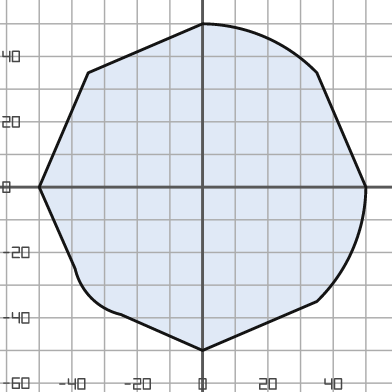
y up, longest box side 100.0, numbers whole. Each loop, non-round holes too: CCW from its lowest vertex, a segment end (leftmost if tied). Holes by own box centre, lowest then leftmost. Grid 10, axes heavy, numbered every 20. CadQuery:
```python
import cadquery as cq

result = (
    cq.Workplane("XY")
    .moveTo(0.0, -50.0)
    .lineTo(35.0, -35.0)
    .threePointArc((46.0, -19.0), (50.0, 0.0))
    .lineTo(35.0, 35.0)
    .threePointArc((19.0, 46.0), (0.0, 50.0))
    .lineTo(-35.0, 35.0)
    .lineTo(-50.0, 0.0)
    .lineTo(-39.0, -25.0)
    .threePointArc((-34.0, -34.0), (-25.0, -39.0))
    .close()
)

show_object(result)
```